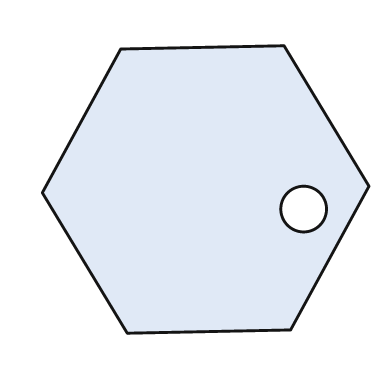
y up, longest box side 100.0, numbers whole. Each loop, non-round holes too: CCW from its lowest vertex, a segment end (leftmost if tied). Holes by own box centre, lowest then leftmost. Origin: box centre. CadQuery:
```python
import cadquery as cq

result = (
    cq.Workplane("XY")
    .moveTo(-24.0, -44.0)
    .lineTo(26.0, -43.0)
    .lineTo(50.0, 1.0)
    .lineTo(24.0, 44.0)
    .lineTo(-26.0, 43.0)
    .lineTo(-50.0, -1.0)
    .close()
    .moveTo(30.0, -6.0)
    .circle(7.0)
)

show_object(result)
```